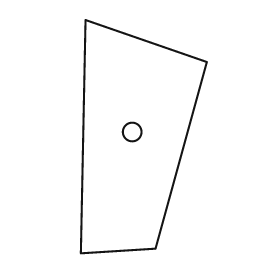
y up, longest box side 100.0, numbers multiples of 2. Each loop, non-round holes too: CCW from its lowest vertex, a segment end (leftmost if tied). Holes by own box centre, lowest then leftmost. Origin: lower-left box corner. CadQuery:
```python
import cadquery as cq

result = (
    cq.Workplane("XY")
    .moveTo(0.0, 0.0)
    .lineTo(32.0, 2.0)
    .lineTo(54.0, 82.0)
    .lineTo(2.0, 100.0)
    .close()
    .moveTo(22.0, 52.0)
    .circle(4.0)
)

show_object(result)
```